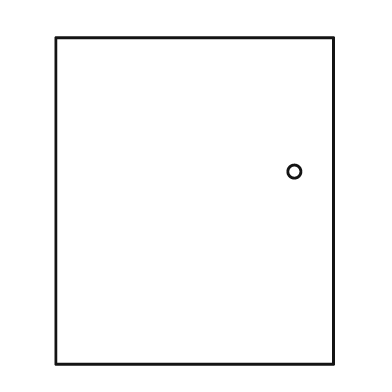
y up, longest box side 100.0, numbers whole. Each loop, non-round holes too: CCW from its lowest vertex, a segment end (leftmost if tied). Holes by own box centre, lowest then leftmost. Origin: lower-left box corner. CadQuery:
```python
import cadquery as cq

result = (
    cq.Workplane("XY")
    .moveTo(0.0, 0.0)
    .lineTo(85.0, 0.0)
    .lineTo(85.0, 100.0)
    .lineTo(0.0, 100.0)
    .close()
    .moveTo(73.0, 59.0)
    .circle(2.0)
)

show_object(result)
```